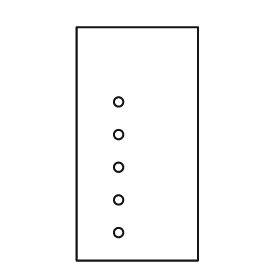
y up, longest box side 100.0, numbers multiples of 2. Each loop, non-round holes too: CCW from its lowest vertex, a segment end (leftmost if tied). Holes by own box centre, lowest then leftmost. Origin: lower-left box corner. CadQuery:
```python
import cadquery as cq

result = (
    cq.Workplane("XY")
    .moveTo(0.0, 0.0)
    .lineTo(52.0, 0.0)
    .lineTo(52.0, 100.0)
    .lineTo(0.0, 100.0)
    .close()
    .moveTo(18.0, 12.0)
    .circle(2.0)
    .moveTo(18.0, 26.0)
    .circle(2.0)
    .moveTo(18.0, 40.0)
    .circle(2.0)
    .moveTo(18.0, 54.0)
    .circle(2.0)
    .moveTo(18.0, 68.0)
    .circle(2.0)
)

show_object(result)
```